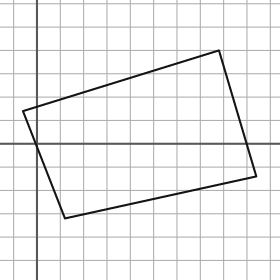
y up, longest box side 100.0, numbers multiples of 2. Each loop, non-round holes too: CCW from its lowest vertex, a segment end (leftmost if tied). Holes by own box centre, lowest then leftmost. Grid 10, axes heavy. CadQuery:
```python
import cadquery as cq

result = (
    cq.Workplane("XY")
    .moveTo(12.0, -32.0)
    .lineTo(94.0, -14.0)
    .lineTo(78.0, 40.0)
    .lineTo(-6.0, 14.0)
    .close()
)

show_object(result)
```